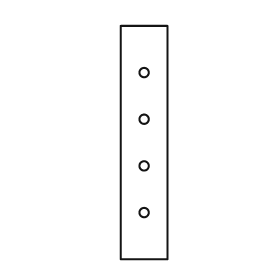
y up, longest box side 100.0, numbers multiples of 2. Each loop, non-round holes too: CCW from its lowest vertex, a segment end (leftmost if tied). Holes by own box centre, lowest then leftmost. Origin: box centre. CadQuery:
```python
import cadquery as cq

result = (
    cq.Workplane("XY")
    .moveTo(-10.0, -50.0)
    .lineTo(10.0, -50.0)
    .lineTo(10.0, 50.0)
    .lineTo(-10.0, 50.0)
    .close()
    .moveTo(0.0, -30.0)
    .circle(2.0)
    .moveTo(0.0, -10.0)
    .circle(2.0)
    .moveTo(0.0, 10.0)
    .circle(2.0)
    .moveTo(0.0, 30.0)
    .circle(2.0)
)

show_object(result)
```